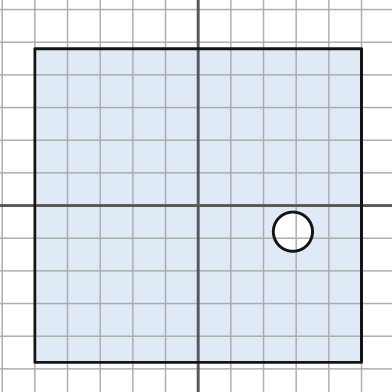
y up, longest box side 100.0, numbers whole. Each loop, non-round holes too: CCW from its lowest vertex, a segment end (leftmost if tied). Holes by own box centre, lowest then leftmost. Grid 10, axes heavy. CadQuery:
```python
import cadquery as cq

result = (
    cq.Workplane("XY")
    .moveTo(-50.0, -48.0)
    .lineTo(50.0, -48.0)
    .lineTo(50.0, 48.0)
    .lineTo(-50.0, 48.0)
    .close()
    .moveTo(29.0, -8.0)
    .circle(6.0)
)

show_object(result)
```